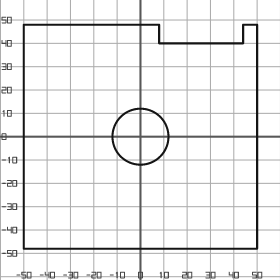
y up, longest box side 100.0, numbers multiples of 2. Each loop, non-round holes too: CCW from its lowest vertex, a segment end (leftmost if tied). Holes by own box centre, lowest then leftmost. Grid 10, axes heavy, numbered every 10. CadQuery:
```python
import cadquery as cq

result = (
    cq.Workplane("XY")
    .moveTo(-50.0, -48.0)
    .lineTo(50.0, -48.0)
    .lineTo(50.0, 48.0)
    .lineTo(44.0, 48.0)
    .lineTo(44.0, 40.0)
    .lineTo(8.0, 40.0)
    .lineTo(8.0, 48.0)
    .lineTo(-50.0, 48.0)
    .close()
    .moveTo(0.0, 0.0)
    .circle(12.0)
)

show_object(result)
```